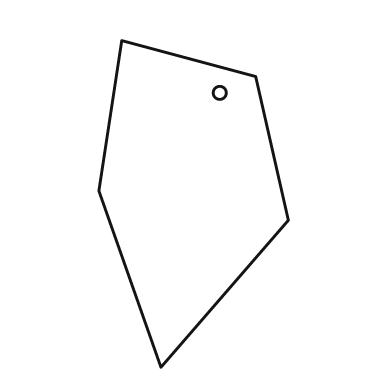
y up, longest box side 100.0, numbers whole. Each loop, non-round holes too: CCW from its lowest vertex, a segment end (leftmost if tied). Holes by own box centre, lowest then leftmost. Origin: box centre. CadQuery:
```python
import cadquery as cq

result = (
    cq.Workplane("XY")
    .moveTo(-10.0, -50.0)
    .lineTo(29.0, -5.0)
    .lineTo(19.0, 39.0)
    .lineTo(-22.0, 50.0)
    .lineTo(-29.0, 4.0)
    .close()
    .moveTo(8.0, 34.0)
    .circle(2.0)
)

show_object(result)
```